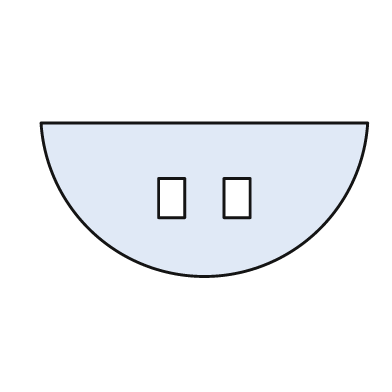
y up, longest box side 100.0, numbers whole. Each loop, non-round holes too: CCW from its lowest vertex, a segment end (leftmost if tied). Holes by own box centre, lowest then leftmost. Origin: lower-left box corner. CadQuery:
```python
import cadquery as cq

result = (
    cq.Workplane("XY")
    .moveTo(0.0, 47.0)
    .threePointArc((50.0, 0.0), (100.0, 47.0))
    .close()
    .moveTo(36.0, 18.0)
    .lineTo(44.0, 18.0)
    .lineTo(44.0, 30.0)
    .lineTo(36.0, 30.0)
    .close()
    .moveTo(56.0, 18.0)
    .lineTo(64.0, 18.0)
    .lineTo(64.0, 30.0)
    .lineTo(56.0, 30.0)
    .close()
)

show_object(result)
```